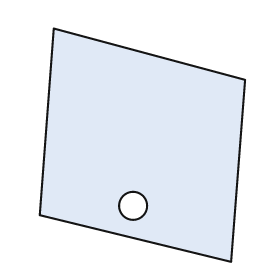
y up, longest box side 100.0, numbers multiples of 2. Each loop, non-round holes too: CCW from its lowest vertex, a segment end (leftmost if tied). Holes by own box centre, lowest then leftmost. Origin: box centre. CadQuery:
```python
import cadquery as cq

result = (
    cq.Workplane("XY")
    .moveTo(38.0, -50.0)
    .lineTo(44.0, 28.0)
    .lineTo(-38.0, 50.0)
    .lineTo(-44.0, -30.0)
    .close()
    .moveTo(-4.0, -26.0)
    .circle(6.0)
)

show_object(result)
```